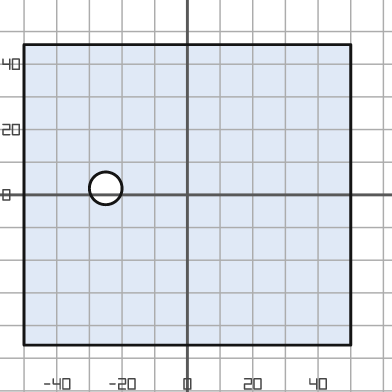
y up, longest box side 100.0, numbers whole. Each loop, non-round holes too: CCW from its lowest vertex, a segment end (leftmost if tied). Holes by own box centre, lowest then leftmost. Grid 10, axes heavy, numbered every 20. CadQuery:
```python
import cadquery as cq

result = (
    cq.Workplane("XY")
    .moveTo(-50.0, -46.0)
    .lineTo(50.0, -46.0)
    .lineTo(50.0, 46.0)
    .lineTo(-50.0, 46.0)
    .close()
    .moveTo(-25.0, 2.0)
    .circle(5.0)
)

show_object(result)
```